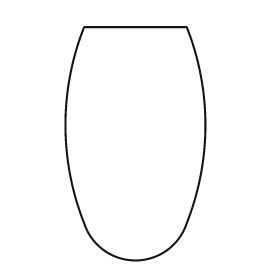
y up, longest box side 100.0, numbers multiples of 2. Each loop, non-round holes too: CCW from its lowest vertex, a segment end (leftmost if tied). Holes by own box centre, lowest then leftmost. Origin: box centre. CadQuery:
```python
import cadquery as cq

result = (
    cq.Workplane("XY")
    .moveTo(-22.0, -34.0)
    .threePointArc((0.0, -50.0), (22.0, -34.0))
    .threePointArc((30.0, 8.0), (22.0, 50.0))
    .lineTo(-22.0, 50.0)
    .threePointArc((-30.0, 8.0), (-22.0, -34.0))
    .close()
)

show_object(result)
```